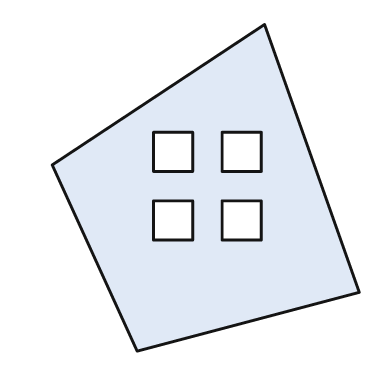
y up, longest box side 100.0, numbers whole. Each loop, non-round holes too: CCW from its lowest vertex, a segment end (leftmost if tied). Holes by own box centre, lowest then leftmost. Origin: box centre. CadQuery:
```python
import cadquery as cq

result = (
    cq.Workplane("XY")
    .moveTo(-21.0, -50.0)
    .lineTo(47.0, -32.0)
    .lineTo(18.0, 50.0)
    .lineTo(-47.0, 7.0)
    .close()
    .moveTo(-16.0, -16.0)
    .lineTo(-4.0, -16.0)
    .lineTo(-4.0, -4.0)
    .lineTo(-16.0, -4.0)
    .close()
    .moveTo(5.0, -16.0)
    .lineTo(17.0, -16.0)
    .lineTo(17.0, -4.0)
    .lineTo(5.0, -4.0)
    .close()
    .moveTo(-16.0, 5.0)
    .lineTo(-4.0, 5.0)
    .lineTo(-4.0, 17.0)
    .lineTo(-16.0, 17.0)
    .close()
    .moveTo(5.0, 5.0)
    .lineTo(17.0, 5.0)
    .lineTo(17.0, 17.0)
    .lineTo(5.0, 17.0)
    .close()
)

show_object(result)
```